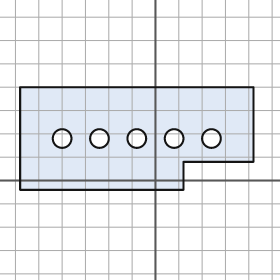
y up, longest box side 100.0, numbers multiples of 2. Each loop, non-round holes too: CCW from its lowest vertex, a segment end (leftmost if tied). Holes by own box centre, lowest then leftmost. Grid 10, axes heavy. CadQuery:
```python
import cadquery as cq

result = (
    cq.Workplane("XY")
    .moveTo(-58.0, -4.0)
    .lineTo(12.0, -4.0)
    .lineTo(12.0, 8.0)
    .lineTo(42.0, 8.0)
    .lineTo(42.0, 40.0)
    .lineTo(-58.0, 40.0)
    .close()
    .moveTo(-40.0, 18.0)
    .circle(4.0)
    .moveTo(-24.0, 18.0)
    .circle(4.0)
    .moveTo(-8.0, 18.0)
    .circle(4.0)
    .moveTo(8.0, 18.0)
    .circle(4.0)
    .moveTo(24.0, 18.0)
    .circle(4.0)
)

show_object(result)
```